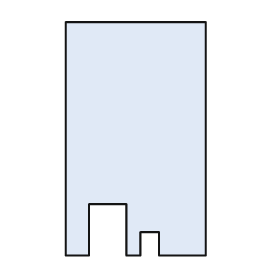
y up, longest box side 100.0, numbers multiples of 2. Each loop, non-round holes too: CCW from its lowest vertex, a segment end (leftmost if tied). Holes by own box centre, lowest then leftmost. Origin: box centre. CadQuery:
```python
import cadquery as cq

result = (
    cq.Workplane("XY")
    .moveTo(-30.0, -50.0)
    .lineTo(-20.0, -50.0)
    .lineTo(-20.0, -28.0)
    .lineTo(-4.0, -28.0)
    .lineTo(-4.0, -50.0)
    .lineTo(2.0, -50.0)
    .lineTo(2.0, -40.0)
    .lineTo(10.0, -40.0)
    .lineTo(10.0, -50.0)
    .lineTo(30.0, -50.0)
    .lineTo(30.0, 50.0)
    .lineTo(-30.0, 50.0)
    .close()
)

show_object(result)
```